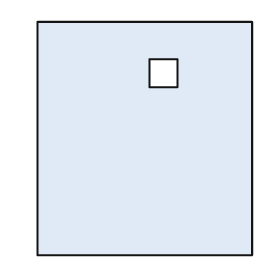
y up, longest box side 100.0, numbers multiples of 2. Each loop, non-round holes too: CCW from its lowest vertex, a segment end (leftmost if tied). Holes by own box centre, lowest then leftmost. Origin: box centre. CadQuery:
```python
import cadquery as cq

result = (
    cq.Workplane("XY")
    .moveTo(-46.0, -50.0)
    .lineTo(46.0, -50.0)
    .lineTo(46.0, 50.0)
    .lineTo(-46.0, 50.0)
    .close()
    .moveTo(2.0, 22.0)
    .lineTo(14.0, 22.0)
    .lineTo(14.0, 34.0)
    .lineTo(2.0, 34.0)
    .close()
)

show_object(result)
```